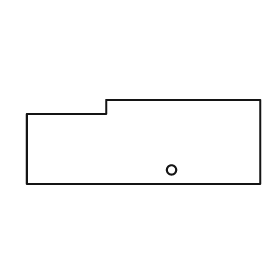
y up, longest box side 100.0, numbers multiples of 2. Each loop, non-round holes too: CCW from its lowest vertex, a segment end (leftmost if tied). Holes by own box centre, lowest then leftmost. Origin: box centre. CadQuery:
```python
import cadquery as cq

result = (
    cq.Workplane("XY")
    .moveTo(-50.0, -18.0)
    .lineTo(50.0, -18.0)
    .lineTo(50.0, 18.0)
    .lineTo(-16.0, 18.0)
    .lineTo(-16.0, 12.0)
    .lineTo(-50.0, 12.0)
    .close()
    .moveTo(12.0, -12.0)
    .circle(2.0)
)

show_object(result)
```